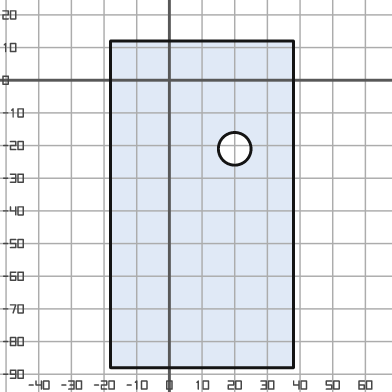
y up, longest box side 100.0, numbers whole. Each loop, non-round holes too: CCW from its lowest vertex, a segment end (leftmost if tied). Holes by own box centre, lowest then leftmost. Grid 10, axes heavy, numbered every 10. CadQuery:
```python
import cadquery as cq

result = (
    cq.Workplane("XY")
    .moveTo(-18.0, -88.0)
    .lineTo(38.0, -88.0)
    .lineTo(38.0, 12.0)
    .lineTo(-18.0, 12.0)
    .close()
    .moveTo(20.0, -21.0)
    .circle(5.0)
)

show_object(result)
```